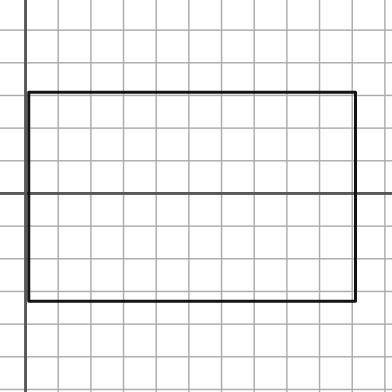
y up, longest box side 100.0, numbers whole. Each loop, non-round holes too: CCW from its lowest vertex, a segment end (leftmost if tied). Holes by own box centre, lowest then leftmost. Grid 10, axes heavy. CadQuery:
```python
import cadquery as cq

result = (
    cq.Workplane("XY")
    .moveTo(1.0, -33.0)
    .lineTo(101.0, -33.0)
    .lineTo(101.0, 31.0)
    .lineTo(1.0, 31.0)
    .close()
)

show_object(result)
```